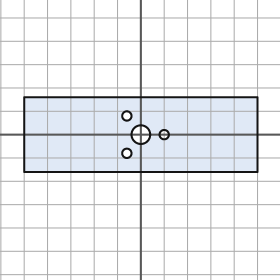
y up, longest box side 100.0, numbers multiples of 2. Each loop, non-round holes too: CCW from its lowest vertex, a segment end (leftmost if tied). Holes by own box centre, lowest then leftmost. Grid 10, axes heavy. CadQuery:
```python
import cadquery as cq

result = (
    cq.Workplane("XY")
    .moveTo(-50.0, -16.0)
    .lineTo(50.0, -16.0)
    .lineTo(50.0, 16.0)
    .lineTo(-50.0, 16.0)
    .close()
    .moveTo(-6.0, -8.0)
    .circle(2.0)
    .moveTo(0.0, 0.0)
    .circle(4.0)
    .moveTo(10.0, 0.0)
    .circle(2.0)
    .moveTo(-6.0, 8.0)
    .circle(2.0)
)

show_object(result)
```